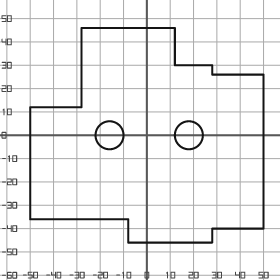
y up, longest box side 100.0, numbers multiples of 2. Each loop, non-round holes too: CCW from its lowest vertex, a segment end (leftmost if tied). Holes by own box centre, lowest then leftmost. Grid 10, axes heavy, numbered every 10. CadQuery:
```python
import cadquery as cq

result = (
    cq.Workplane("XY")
    .moveTo(-8.0, -46.0)
    .lineTo(28.0, -46.0)
    .lineTo(28.0, -40.0)
    .lineTo(50.0, -40.0)
    .lineTo(50.0, 26.0)
    .lineTo(28.0, 26.0)
    .lineTo(28.0, 30.0)
    .lineTo(12.0, 30.0)
    .lineTo(12.0, 46.0)
    .lineTo(-28.0, 46.0)
    .lineTo(-28.0, 12.0)
    .lineTo(-50.0, 12.0)
    .lineTo(-50.0, -36.0)
    .lineTo(-8.0, -36.0)
    .close()
    .moveTo(-16.0, 0.0)
    .circle(6.0)
    .moveTo(18.0, 0.0)
    .circle(6.0)
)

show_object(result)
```